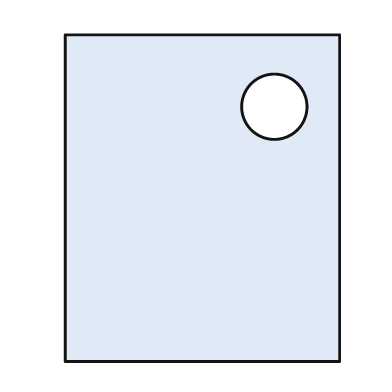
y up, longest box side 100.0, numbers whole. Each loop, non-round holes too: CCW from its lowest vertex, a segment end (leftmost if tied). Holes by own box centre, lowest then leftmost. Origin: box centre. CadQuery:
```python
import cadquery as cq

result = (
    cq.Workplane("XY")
    .moveTo(-42.0, -50.0)
    .lineTo(42.0, -50.0)
    .lineTo(42.0, 50.0)
    .lineTo(-42.0, 50.0)
    .close()
    .moveTo(22.0, 28.0)
    .circle(10.0)
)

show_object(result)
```